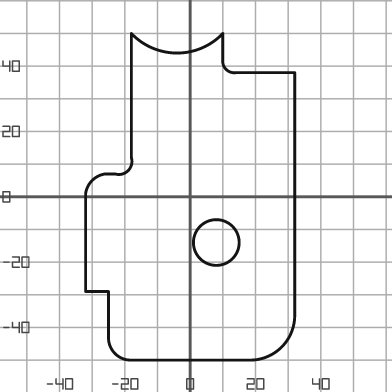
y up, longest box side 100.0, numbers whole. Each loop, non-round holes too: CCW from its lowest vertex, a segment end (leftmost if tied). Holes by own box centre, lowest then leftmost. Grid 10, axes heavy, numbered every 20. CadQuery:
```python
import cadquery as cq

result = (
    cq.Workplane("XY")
    .moveTo(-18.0, -50.0)
    .lineTo(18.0, -50.0)
    .threePointArc((28.0, -46.0), (32.0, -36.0))
    .lineTo(32.0, 38.0)
    .lineTo(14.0, 38.0)
    .threePointArc((11.0, 39.0), (10.0, 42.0))
    .lineTo(10.0, 50.0)
    .threePointArc((-4.0, 44.0), (-18.0, 50.0))
    .lineTo(-18.0, 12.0)
    .threePointArc((-19.0, 8.0), (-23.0, 7.0))
    .lineTo(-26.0, 7.0)
    .threePointArc((-30.0, 5.0), (-32.0, 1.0))
    .lineTo(-32.0, -29.0)
    .lineTo(-25.0, -29.0)
    .lineTo(-25.0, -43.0)
    .threePointArc((-23.0, -48.0), (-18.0, -50.0))
    .close()
    .moveTo(8.0, -14.0)
    .circle(7.0)
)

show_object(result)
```